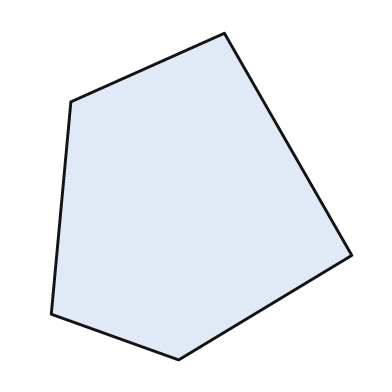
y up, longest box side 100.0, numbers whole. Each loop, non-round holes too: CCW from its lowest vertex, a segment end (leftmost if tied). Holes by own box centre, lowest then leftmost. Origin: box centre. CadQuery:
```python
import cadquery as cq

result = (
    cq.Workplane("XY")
    .moveTo(-7.0, -50.0)
    .lineTo(46.0, -18.0)
    .lineTo(7.0, 50.0)
    .lineTo(-40.0, 29.0)
    .lineTo(-46.0, -36.0)
    .close()
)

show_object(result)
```